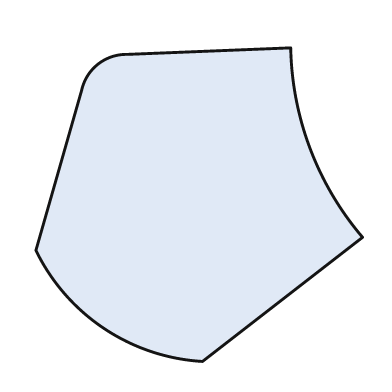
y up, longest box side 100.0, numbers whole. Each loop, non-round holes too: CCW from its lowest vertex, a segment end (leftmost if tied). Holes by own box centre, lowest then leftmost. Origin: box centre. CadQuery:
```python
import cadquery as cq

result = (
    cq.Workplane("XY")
    .moveTo(1.0, -48.0)
    .lineTo(50.0, -10.0)
    .threePointArc((34.0, 17.0), (28.0, 48.0))
    .lineTo(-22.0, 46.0)
    .threePointArc((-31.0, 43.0), (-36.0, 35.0))
    .lineTo(-50.0, -14.0)
    .threePointArc((-29.0, -38.0), (1.0, -48.0))
    .close()
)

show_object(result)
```